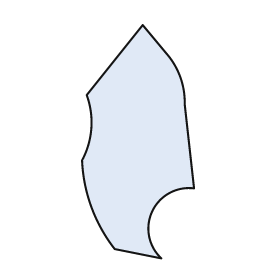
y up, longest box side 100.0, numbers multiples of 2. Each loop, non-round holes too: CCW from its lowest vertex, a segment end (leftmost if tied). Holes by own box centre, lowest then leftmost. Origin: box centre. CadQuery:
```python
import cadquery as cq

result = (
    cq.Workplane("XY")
    .moveTo(10.0, -50.0)
    .threePointArc((6.0, -30.0), (24.0, -20.0))
    .lineTo(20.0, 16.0)
    .threePointArc((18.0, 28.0), (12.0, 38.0))
    .lineTo(2.0, 50.0)
    .lineTo(-22.0, 20.0)
    .threePointArc((-20.0, 6.0), (-24.0, -8.0))
    .threePointArc((-20.0, -28.0), (-10.0, -46.0))
    .close()
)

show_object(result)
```